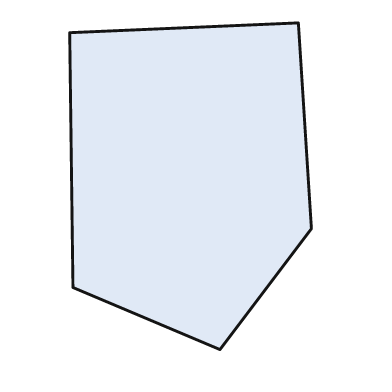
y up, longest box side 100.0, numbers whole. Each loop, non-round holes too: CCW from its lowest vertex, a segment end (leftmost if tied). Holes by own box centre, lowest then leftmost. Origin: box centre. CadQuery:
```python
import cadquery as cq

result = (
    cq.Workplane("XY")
    .moveTo(9.0, -50.0)
    .lineTo(37.0, -13.0)
    .lineTo(33.0, 50.0)
    .lineTo(-37.0, 47.0)
    .lineTo(-36.0, -31.0)
    .close()
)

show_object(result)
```